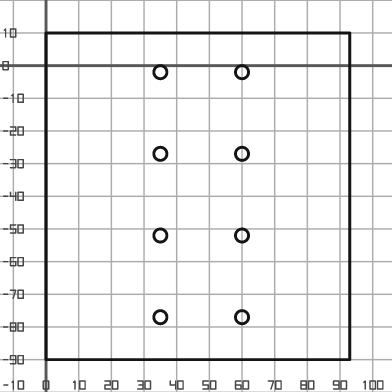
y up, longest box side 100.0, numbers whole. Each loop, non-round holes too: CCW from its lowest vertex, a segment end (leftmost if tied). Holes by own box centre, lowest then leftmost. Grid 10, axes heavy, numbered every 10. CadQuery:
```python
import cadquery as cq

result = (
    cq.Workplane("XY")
    .moveTo(0.0, -90.0)
    .lineTo(93.0, -90.0)
    .lineTo(93.0, 10.0)
    .lineTo(0.0, 10.0)
    .close()
    .moveTo(35.0, -77.0)
    .circle(2.0)
    .moveTo(60.0, -77.0)
    .circle(2.0)
    .moveTo(35.0, -52.0)
    .circle(2.0)
    .moveTo(60.0, -52.0)
    .circle(2.0)
    .moveTo(35.0, -27.0)
    .circle(2.0)
    .moveTo(60.0, -27.0)
    .circle(2.0)
    .moveTo(35.0, -2.0)
    .circle(2.0)
    .moveTo(60.0, -2.0)
    .circle(2.0)
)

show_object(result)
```